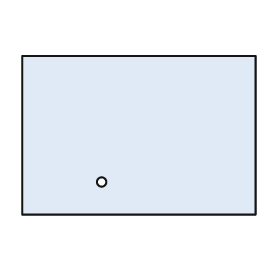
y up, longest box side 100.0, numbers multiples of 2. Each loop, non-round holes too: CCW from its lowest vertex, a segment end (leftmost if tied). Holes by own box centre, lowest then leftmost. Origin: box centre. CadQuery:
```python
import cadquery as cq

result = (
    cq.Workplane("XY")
    .moveTo(-50.0, -34.0)
    .lineTo(50.0, -34.0)
    .lineTo(50.0, 34.0)
    .lineTo(-50.0, 34.0)
    .close()
    .moveTo(-16.0, -20.0)
    .circle(2.0)
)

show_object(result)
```